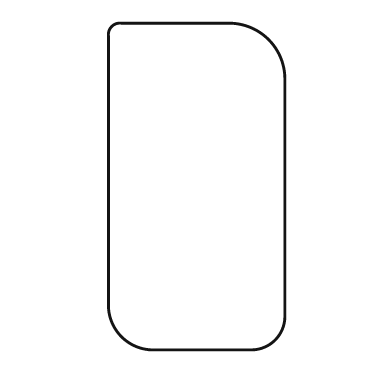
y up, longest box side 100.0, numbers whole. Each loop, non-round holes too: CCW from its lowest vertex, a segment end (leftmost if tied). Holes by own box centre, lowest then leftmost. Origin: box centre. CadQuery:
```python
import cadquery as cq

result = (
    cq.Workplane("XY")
    .moveTo(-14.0, -50.0)
    .lineTo(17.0, -50.0)
    .threePointArc((24.0, -47.0), (27.0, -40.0))
    .lineTo(27.0, 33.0)
    .threePointArc((22.0, 45.0), (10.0, 50.0))
    .lineTo(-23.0, 50.0)
    .threePointArc((-26.0, 49.0), (-27.0, 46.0))
    .lineTo(-27.0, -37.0)
    .threePointArc((-23.0, -46.0), (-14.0, -50.0))
    .close()
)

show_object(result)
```